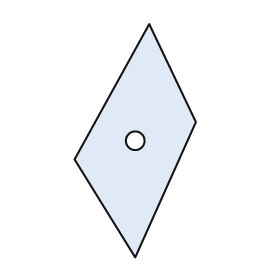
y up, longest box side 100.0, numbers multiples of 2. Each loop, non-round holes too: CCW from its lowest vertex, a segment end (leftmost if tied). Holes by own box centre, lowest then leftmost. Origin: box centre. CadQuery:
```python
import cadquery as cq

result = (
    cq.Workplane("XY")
    .moveTo(0.0, -50.0)
    .lineTo(26.0, 8.0)
    .lineTo(6.0, 50.0)
    .lineTo(-26.0, -8.0)
    .close()
    .moveTo(0.0, 0.0)
    .circle(4.0)
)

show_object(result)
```